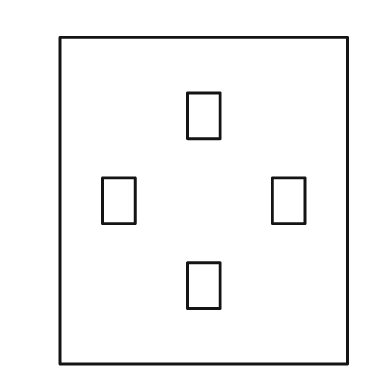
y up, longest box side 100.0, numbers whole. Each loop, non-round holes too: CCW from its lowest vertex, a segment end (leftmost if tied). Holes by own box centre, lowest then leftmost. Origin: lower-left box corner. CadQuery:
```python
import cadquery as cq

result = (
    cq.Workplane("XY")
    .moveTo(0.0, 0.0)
    .lineTo(88.0, 0.0)
    .lineTo(88.0, 100.0)
    .lineTo(0.0, 100.0)
    .close()
    .moveTo(39.0, 17.0)
    .lineTo(49.0, 17.0)
    .lineTo(49.0, 31.0)
    .lineTo(39.0, 31.0)
    .close()
    .moveTo(13.0, 43.0)
    .lineTo(23.0, 43.0)
    .lineTo(23.0, 57.0)
    .lineTo(13.0, 57.0)
    .close()
    .moveTo(65.0, 43.0)
    .lineTo(75.0, 43.0)
    .lineTo(75.0, 57.0)
    .lineTo(65.0, 57.0)
    .close()
    .moveTo(39.0, 69.0)
    .lineTo(49.0, 69.0)
    .lineTo(49.0, 83.0)
    .lineTo(39.0, 83.0)
    .close()
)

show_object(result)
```